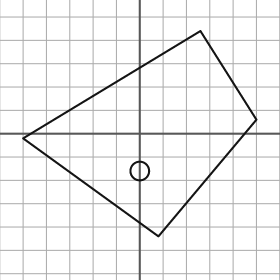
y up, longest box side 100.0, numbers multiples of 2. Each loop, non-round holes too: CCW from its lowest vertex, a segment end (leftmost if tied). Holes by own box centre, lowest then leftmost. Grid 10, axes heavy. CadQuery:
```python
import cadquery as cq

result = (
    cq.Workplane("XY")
    .moveTo(8.0, -44.0)
    .lineTo(50.0, 6.0)
    .lineTo(26.0, 44.0)
    .lineTo(-50.0, -2.0)
    .close()
    .moveTo(0.0, -16.0)
    .circle(4.0)
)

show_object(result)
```